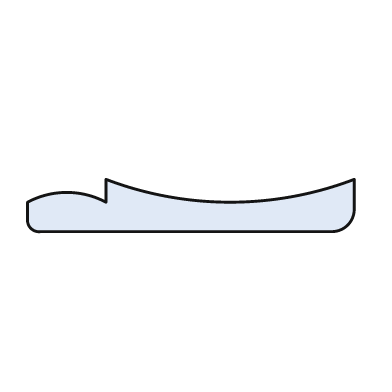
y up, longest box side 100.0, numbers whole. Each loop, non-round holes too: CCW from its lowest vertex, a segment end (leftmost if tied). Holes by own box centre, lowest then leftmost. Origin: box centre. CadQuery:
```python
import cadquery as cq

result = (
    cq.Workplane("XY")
    .moveTo(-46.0, -8.0)
    .lineTo(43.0, -8.0)
    .threePointArc((48.0, -6.0), (50.0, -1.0))
    .lineTo(50.0, 8.0)
    .threePointArc((12.0, 1.0), (-26.0, 8.0))
    .lineTo(-26.0, 1.0)
    .threePointArc((-38.0, 4.0), (-50.0, 1.0))
    .lineTo(-50.0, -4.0)
    .threePointArc((-49.0, -7.0), (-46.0, -8.0))
    .close()
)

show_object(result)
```